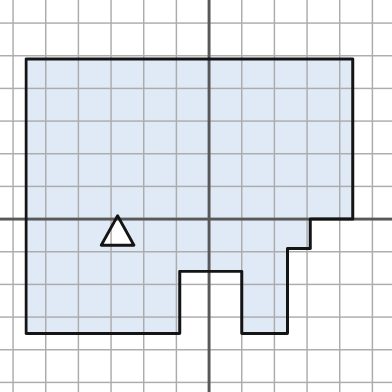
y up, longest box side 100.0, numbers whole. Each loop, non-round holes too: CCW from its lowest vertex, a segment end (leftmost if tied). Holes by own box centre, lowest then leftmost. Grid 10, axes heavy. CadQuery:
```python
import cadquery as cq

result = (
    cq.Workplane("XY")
    .moveTo(-56.0, -35.0)
    .lineTo(-9.0, -35.0)
    .lineTo(-9.0, -16.0)
    .lineTo(10.0, -16.0)
    .lineTo(10.0, -35.0)
    .lineTo(24.0, -35.0)
    .lineTo(24.0, -9.0)
    .lineTo(31.0, -9.0)
    .lineTo(31.0, 0.0)
    .lineTo(44.0, 0.0)
    .lineTo(44.0, 49.0)
    .lineTo(-56.0, 49.0)
    .close()
    .moveTo(-33.0, -8.0)
    .lineTo(-23.0, -8.0)
    .lineTo(-28.0, 1.0)
    .close()
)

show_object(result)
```